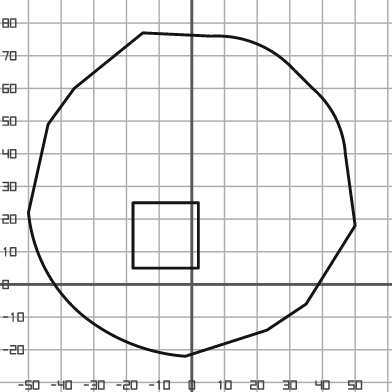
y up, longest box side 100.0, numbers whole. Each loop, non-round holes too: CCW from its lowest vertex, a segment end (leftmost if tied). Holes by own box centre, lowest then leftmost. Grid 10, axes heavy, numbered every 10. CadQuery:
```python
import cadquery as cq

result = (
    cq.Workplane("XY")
    .moveTo(-2.0, -22.0)
    .lineTo(23.0, -14.0)
    .lineTo(35.0, -6.0)
    .lineTo(50.0, 18.0)
    .lineTo(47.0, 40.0)
    .threePointArc((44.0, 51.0), (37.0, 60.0))
    .lineTo(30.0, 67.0)
    .threePointArc((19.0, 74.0), (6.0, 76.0))
    .lineTo(-15.0, 77.0)
    .lineTo(-36.0, 60.0)
    .lineTo(-44.0, 49.0)
    .lineTo(-50.0, 22.0)
    .threePointArc((-45.0, 5.0), (-34.0, -9.0))
    .threePointArc((-19.0, -18.0), (-2.0, -22.0))
    .close()
    .moveTo(-18.0, 5.0)
    .lineTo(2.0, 5.0)
    .lineTo(2.0, 25.0)
    .lineTo(-18.0, 25.0)
    .close()
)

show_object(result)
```